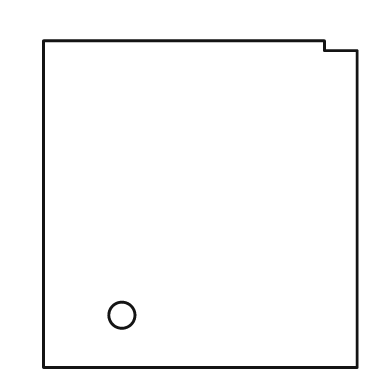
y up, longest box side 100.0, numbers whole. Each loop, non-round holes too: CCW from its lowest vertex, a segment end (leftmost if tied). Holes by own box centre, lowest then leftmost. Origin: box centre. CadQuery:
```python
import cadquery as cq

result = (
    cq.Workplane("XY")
    .moveTo(-48.0, -50.0)
    .lineTo(48.0, -50.0)
    .lineTo(48.0, 47.0)
    .lineTo(38.0, 47.0)
    .lineTo(38.0, 50.0)
    .lineTo(-48.0, 50.0)
    .close()
    .moveTo(-24.0, -34.0)
    .circle(4.0)
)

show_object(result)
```